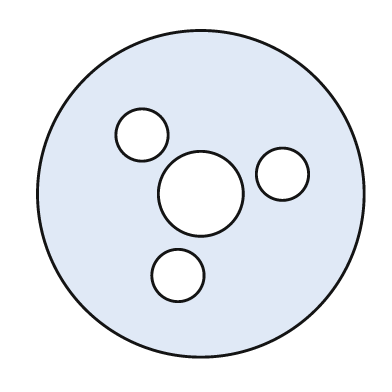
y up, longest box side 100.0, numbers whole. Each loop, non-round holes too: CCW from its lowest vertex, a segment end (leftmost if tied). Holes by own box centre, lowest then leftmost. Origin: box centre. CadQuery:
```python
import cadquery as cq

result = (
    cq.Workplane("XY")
    .moveTo(0.0, 0.0)
    .circle(50.0)
    .moveTo(-7.0, -25.0)
    .circle(8.0)
    .moveTo(0.0, 0.0)
    .circle(13.0)
    .moveTo(25.0, 6.0)
    .circle(8.0)
    .moveTo(-18.0, 18.0)
    .circle(8.0)
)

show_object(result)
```